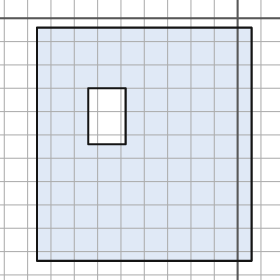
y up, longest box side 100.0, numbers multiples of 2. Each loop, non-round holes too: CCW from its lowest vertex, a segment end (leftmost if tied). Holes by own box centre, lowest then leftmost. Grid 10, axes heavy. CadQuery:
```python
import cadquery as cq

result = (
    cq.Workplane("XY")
    .moveTo(-86.0, -104.0)
    .lineTo(6.0, -104.0)
    .lineTo(6.0, -4.0)
    .lineTo(-86.0, -4.0)
    .close()
    .moveTo(-64.0, -54.0)
    .lineTo(-48.0, -54.0)
    .lineTo(-48.0, -30.0)
    .lineTo(-64.0, -30.0)
    .close()
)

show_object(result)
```